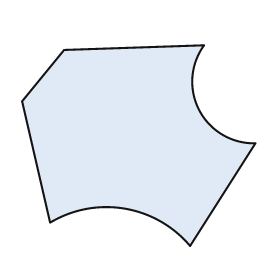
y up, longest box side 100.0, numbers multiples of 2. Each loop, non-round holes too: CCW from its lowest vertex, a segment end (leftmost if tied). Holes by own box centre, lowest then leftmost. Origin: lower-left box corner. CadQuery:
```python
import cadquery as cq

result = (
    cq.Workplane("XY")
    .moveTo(72.0, 0.0)
    .lineTo(100.0, 44.0)
    .threePointArc((76.0, 58.0), (78.0, 86.0))
    .lineTo(18.0, 84.0)
    .lineTo(0.0, 62.0)
    .lineTo(12.0, 10.0)
    .threePointArc((44.0, 16.0), (72.0, 0.0))
    .close()
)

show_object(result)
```